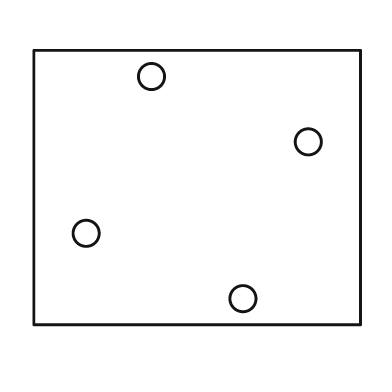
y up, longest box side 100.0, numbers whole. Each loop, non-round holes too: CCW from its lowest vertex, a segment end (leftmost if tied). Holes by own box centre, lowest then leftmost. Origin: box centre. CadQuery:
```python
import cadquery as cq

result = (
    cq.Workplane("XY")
    .moveTo(-50.0, -42.0)
    .lineTo(50.0, -42.0)
    .lineTo(50.0, 42.0)
    .lineTo(-50.0, 42.0)
    .close()
    .moveTo(14.0, -34.0)
    .circle(4.0)
    .moveTo(-34.0, -14.0)
    .circle(4.0)
    .moveTo(34.0, 14.0)
    .circle(4.0)
    .moveTo(-14.0, 34.0)
    .circle(4.0)
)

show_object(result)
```